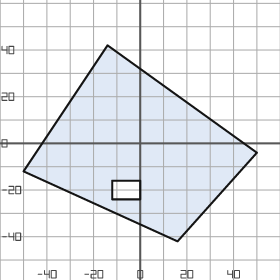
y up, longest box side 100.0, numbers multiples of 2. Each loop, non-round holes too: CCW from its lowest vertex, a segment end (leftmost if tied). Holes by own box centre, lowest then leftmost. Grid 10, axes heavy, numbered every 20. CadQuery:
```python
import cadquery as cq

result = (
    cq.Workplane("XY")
    .moveTo(16.0, -42.0)
    .lineTo(50.0, -4.0)
    .lineTo(-14.0, 42.0)
    .lineTo(-50.0, -12.0)
    .close()
    .moveTo(-12.0, -24.0)
    .lineTo(0.0, -24.0)
    .lineTo(0.0, -16.0)
    .lineTo(-12.0, -16.0)
    .close()
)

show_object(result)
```